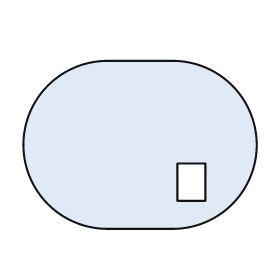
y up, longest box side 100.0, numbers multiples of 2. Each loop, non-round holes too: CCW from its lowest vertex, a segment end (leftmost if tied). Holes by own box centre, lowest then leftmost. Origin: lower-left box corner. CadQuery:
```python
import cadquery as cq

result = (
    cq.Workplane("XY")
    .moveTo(36.0, 0.0)
    .lineTo(64.0, 0.0)
    .threePointArc((100.0, 36.0), (64.0, 72.0))
    .lineTo(36.0, 72.0)
    .threePointArc((0.0, 36.0), (36.0, 0.0))
    .close()
    .moveTo(66.0, 12.0)
    .lineTo(78.0, 12.0)
    .lineTo(78.0, 28.0)
    .lineTo(66.0, 28.0)
    .close()
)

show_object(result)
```